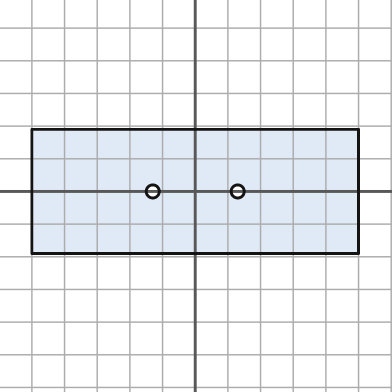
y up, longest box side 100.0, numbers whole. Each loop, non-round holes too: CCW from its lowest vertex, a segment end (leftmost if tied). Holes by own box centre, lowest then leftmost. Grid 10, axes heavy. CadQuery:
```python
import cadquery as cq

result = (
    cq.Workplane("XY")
    .moveTo(-50.0, -19.0)
    .lineTo(50.0, -19.0)
    .lineTo(50.0, 19.0)
    .lineTo(-50.0, 19.0)
    .close()
    .moveTo(-13.0, 0.0)
    .circle(2.0)
    .moveTo(13.0, 0.0)
    .circle(2.0)
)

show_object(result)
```